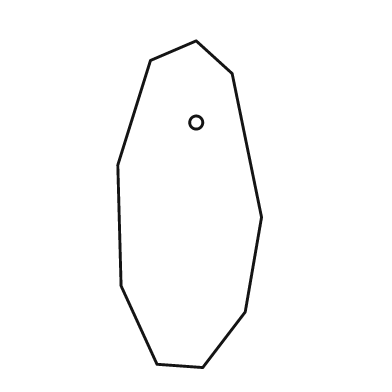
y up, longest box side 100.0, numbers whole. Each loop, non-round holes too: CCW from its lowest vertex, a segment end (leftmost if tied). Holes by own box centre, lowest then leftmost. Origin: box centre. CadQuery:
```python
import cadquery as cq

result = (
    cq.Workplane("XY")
    .moveTo(4.0, -50.0)
    .lineTo(17.0, -33.0)
    .lineTo(22.0, -4.0)
    .lineTo(13.0, 40.0)
    .lineTo(2.0, 50.0)
    .lineTo(-12.0, 44.0)
    .lineTo(-22.0, 12.0)
    .lineTo(-21.0, -25.0)
    .lineTo(-10.0, -49.0)
    .close()
    .moveTo(2.0, 25.0)
    .circle(2.0)
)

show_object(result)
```